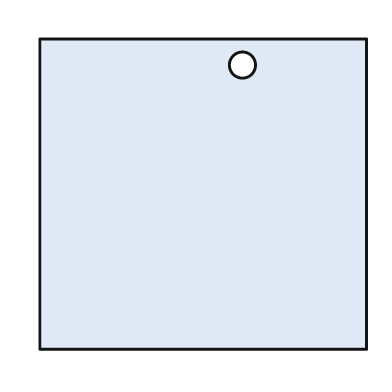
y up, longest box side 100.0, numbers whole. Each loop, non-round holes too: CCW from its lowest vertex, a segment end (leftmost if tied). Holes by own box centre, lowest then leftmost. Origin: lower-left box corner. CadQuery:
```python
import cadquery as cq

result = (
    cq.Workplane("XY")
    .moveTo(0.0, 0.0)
    .lineTo(100.0, 0.0)
    .lineTo(100.0, 95.0)
    .lineTo(0.0, 95.0)
    .close()
    .moveTo(62.0, 87.0)
    .circle(4.0)
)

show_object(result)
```